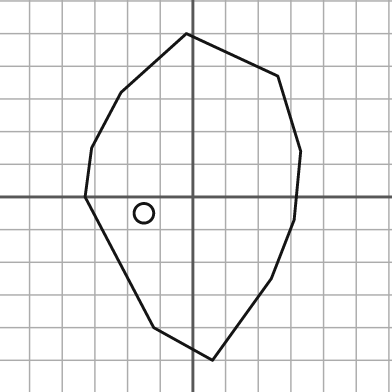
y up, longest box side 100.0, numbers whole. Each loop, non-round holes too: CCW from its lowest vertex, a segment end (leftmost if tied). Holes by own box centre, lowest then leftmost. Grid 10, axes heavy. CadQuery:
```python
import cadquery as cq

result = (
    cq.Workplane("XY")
    .moveTo(6.0, -50.0)
    .lineTo(24.0, -25.0)
    .lineTo(31.0, -7.0)
    .lineTo(33.0, 14.0)
    .lineTo(26.0, 37.0)
    .lineTo(-2.0, 50.0)
    .lineTo(-22.0, 32.0)
    .lineTo(-31.0, 15.0)
    .lineTo(-33.0, 0.0)
    .lineTo(-12.0, -40.0)
    .close()
    .moveTo(-15.0, -5.0)
    .circle(3.0)
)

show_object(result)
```